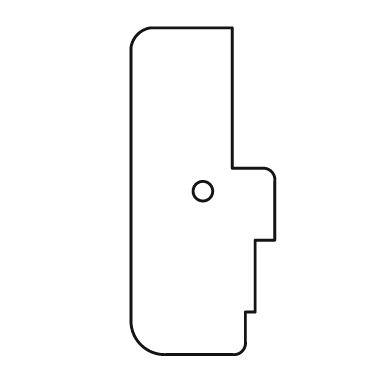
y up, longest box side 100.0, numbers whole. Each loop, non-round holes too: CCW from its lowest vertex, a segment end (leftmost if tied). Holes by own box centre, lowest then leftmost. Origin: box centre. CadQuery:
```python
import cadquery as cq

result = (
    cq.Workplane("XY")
    .moveTo(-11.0, -50.0)
    .lineTo(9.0, -50.0)
    .threePointArc((12.0, -49.0), (13.0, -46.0))
    .lineTo(13.0, -37.0)
    .lineTo(16.0, -37.0)
    .lineTo(16.0, -15.0)
    .lineTo(22.0, -15.0)
    .lineTo(22.0, 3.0)
    .threePointArc((21.0, 6.0), (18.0, 7.0))
    .lineTo(9.0, 7.0)
    .lineTo(9.0, 50.0)
    .lineTo(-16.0, 50.0)
    .threePointArc((-20.0, 48.0), (-22.0, 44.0))
    .lineTo(-22.0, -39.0)
    .threePointArc((-19.0, -47.0), (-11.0, -50.0))
    .close()
    .moveTo(0.0, 0.0)
    .circle(3.0)
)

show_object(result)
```